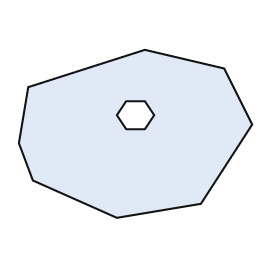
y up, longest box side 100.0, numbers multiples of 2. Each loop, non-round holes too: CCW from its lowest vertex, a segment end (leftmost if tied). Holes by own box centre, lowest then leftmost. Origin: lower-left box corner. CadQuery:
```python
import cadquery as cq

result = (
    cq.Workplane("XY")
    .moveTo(42.0, 0.0)
    .lineTo(78.0, 6.0)
    .lineTo(100.0, 40.0)
    .lineTo(88.0, 64.0)
    .lineTo(54.0, 72.0)
    .lineTo(4.0, 56.0)
    .lineTo(0.0, 32.0)
    .lineTo(6.0, 16.0)
    .close()
    .moveTo(46.0, 38.0)
    .lineTo(54.0, 38.0)
    .lineTo(58.0, 44.0)
    .lineTo(54.0, 50.0)
    .lineTo(46.0, 50.0)
    .lineTo(42.0, 44.0)
    .close()
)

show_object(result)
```